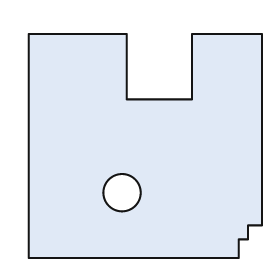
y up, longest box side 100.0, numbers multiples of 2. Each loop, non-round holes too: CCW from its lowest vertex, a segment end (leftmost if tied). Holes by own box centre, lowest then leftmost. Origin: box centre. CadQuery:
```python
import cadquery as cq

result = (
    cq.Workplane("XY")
    .moveTo(-50.0, -48.0)
    .lineTo(40.0, -48.0)
    .lineTo(40.0, -40.0)
    .lineTo(44.0, -40.0)
    .lineTo(44.0, -34.0)
    .lineTo(50.0, -34.0)
    .lineTo(50.0, 48.0)
    .lineTo(20.0, 48.0)
    .lineTo(20.0, 20.0)
    .lineTo(-8.0, 20.0)
    .lineTo(-8.0, 48.0)
    .lineTo(-50.0, 48.0)
    .close()
    .moveTo(-10.0, -20.0)
    .circle(8.0)
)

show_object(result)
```